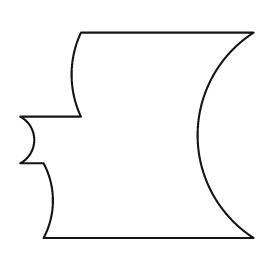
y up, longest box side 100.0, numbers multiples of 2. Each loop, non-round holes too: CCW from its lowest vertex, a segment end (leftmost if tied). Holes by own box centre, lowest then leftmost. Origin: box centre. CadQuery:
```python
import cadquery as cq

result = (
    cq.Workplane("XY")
    .moveTo(-40.0, -44.0)
    .lineTo(50.0, -44.0)
    .threePointArc((26.0, 0.0), (50.0, 44.0))
    .lineTo(-24.0, 44.0)
    .threePointArc((-28.0, 26.0), (-24.0, 8.0))
    .lineTo(-50.0, 8.0)
    .threePointArc((-44.0, -2.0), (-50.0, -12.0))
    .lineTo(-40.0, -12.0)
    .threePointArc((-36.0, -28.0), (-40.0, -44.0))
    .close()
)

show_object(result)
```